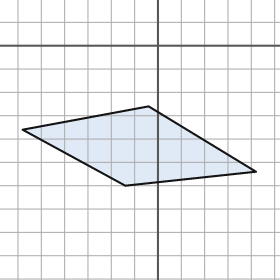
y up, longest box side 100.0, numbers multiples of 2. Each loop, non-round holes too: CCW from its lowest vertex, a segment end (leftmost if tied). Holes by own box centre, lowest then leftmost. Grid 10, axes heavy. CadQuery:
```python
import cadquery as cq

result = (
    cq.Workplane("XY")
    .moveTo(-14.0, -60.0)
    .lineTo(42.0, -54.0)
    .lineTo(-4.0, -26.0)
    .lineTo(-58.0, -36.0)
    .close()
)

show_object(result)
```